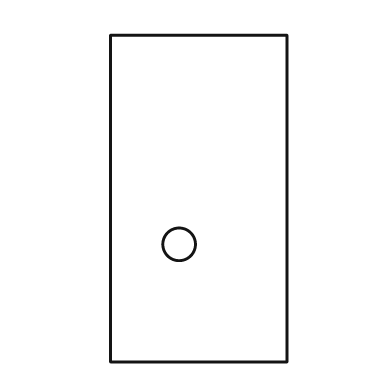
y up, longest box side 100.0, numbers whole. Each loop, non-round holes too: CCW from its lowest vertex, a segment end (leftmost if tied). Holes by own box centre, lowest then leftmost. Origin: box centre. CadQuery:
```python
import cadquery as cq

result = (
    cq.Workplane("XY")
    .moveTo(-27.0, -50.0)
    .lineTo(27.0, -50.0)
    .lineTo(27.0, 50.0)
    .lineTo(-27.0, 50.0)
    .close()
    .moveTo(-6.0, -14.0)
    .circle(5.0)
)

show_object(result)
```